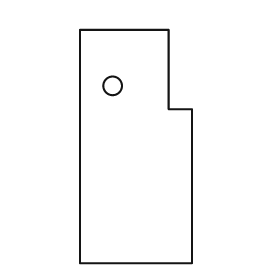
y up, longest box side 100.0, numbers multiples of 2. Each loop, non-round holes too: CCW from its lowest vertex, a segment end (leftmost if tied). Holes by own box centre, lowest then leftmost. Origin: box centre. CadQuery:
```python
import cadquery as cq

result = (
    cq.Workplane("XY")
    .moveTo(-24.0, -50.0)
    .lineTo(24.0, -50.0)
    .lineTo(24.0, 16.0)
    .lineTo(14.0, 16.0)
    .lineTo(14.0, 50.0)
    .lineTo(-24.0, 50.0)
    .close()
    .moveTo(-10.0, 26.0)
    .circle(4.0)
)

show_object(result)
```